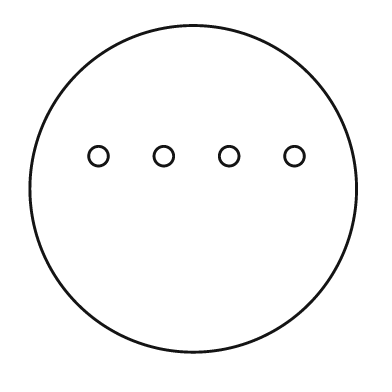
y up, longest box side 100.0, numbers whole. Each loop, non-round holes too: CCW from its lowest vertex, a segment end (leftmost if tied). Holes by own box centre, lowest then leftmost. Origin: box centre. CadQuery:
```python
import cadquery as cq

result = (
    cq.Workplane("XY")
    .moveTo(0.0, 0.0)
    .circle(50.0)
    .moveTo(-29.0, 10.0)
    .circle(3.0)
    .moveTo(-9.0, 10.0)
    .circle(3.0)
    .moveTo(11.0, 10.0)
    .circle(3.0)
    .moveTo(31.0, 10.0)
    .circle(3.0)
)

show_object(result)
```